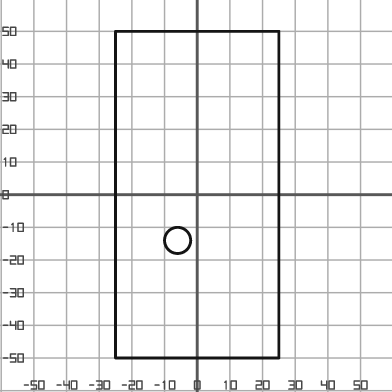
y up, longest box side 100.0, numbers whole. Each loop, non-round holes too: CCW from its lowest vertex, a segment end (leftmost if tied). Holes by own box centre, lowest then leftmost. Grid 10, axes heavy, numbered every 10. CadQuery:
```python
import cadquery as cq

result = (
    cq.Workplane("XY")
    .moveTo(-25.0, -50.0)
    .lineTo(25.0, -50.0)
    .lineTo(25.0, 50.0)
    .lineTo(-25.0, 50.0)
    .close()
    .moveTo(-6.0, -14.0)
    .circle(4.0)
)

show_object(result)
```